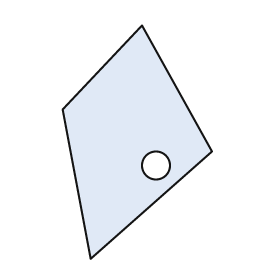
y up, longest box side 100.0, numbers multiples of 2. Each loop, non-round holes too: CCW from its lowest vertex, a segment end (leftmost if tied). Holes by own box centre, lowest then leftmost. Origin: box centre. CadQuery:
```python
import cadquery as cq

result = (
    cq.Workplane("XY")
    .moveTo(-20.0, -50.0)
    .lineTo(32.0, -4.0)
    .lineTo(2.0, 50.0)
    .lineTo(-32.0, 14.0)
    .close()
    .moveTo(8.0, -10.0)
    .circle(6.0)
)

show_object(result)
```